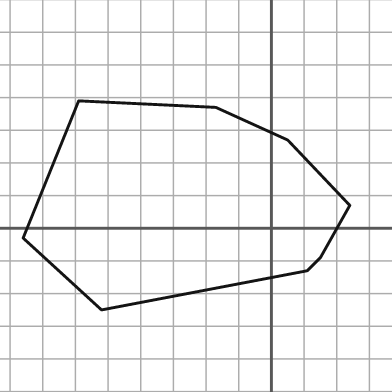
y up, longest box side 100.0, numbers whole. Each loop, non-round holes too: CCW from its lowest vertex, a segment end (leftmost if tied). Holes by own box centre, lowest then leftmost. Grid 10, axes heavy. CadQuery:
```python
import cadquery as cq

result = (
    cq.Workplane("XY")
    .moveTo(-52.0, -25.0)
    .lineTo(11.0, -13.0)
    .lineTo(15.0, -9.0)
    .lineTo(24.0, 7.0)
    .lineTo(5.0, 27.0)
    .lineTo(-17.0, 37.0)
    .lineTo(-59.0, 39.0)
    .lineTo(-76.0, -3.0)
    .close()
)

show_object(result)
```